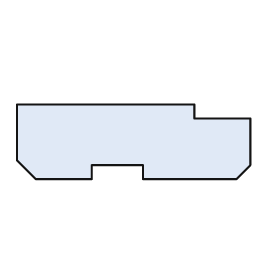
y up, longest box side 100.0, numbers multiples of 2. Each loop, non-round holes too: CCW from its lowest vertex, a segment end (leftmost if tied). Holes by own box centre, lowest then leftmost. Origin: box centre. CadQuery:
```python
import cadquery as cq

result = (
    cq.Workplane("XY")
    .moveTo(-42.0, -16.0)
    .lineTo(-18.0, -16.0)
    .lineTo(-18.0, -10.0)
    .lineTo(4.0, -10.0)
    .lineTo(4.0, -16.0)
    .lineTo(44.0, -16.0)
    .lineTo(50.0, -10.0)
    .lineTo(50.0, 10.0)
    .lineTo(26.0, 10.0)
    .lineTo(26.0, 16.0)
    .lineTo(-50.0, 16.0)
    .lineTo(-50.0, -8.0)
    .close()
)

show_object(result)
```